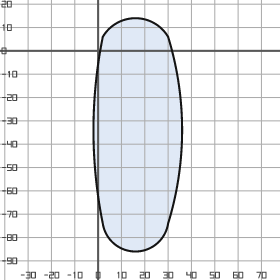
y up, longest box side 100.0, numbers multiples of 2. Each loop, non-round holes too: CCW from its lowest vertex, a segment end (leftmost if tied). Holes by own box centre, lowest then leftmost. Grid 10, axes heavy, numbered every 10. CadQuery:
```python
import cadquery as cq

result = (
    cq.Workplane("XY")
    .moveTo(2.0, -74.0)
    .threePointArc((16.0, -86.0), (30.0, -74.0))
    .threePointArc((36.0, -34.0), (30.0, 6.0))
    .threePointArc((16.0, 14.0), (2.0, 6.0))
    .threePointArc((-2.0, -34.0), (2.0, -74.0))
    .close()
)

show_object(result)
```